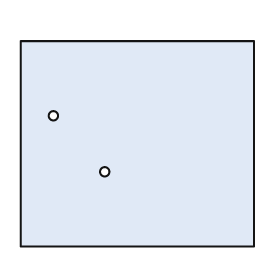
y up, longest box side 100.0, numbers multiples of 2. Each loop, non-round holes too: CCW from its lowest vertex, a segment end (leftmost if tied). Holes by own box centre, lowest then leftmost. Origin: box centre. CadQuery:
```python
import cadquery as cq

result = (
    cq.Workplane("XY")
    .moveTo(-50.0, -44.0)
    .lineTo(50.0, -44.0)
    .lineTo(50.0, 44.0)
    .lineTo(-50.0, 44.0)
    .close()
    .moveTo(-14.0, -12.0)
    .circle(2.0)
    .moveTo(-36.0, 12.0)
    .circle(2.0)
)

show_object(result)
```